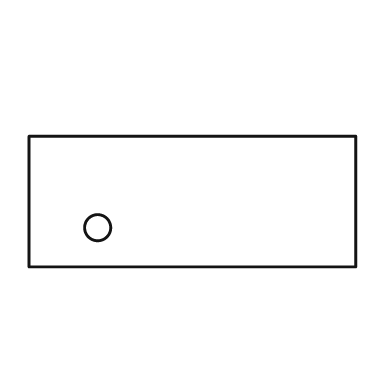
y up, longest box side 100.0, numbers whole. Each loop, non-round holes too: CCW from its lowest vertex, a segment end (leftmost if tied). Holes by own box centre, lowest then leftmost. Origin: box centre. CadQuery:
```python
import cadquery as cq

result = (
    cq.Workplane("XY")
    .moveTo(-50.0, -20.0)
    .lineTo(50.0, -20.0)
    .lineTo(50.0, 20.0)
    .lineTo(-50.0, 20.0)
    .close()
    .moveTo(-29.0, -8.0)
    .circle(4.0)
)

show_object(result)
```